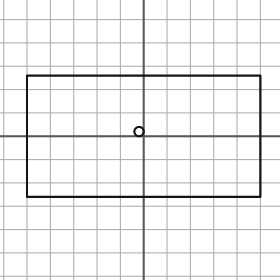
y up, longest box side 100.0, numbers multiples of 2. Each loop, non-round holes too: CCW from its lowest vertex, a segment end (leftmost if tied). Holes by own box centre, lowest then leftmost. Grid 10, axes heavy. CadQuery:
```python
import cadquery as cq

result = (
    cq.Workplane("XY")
    .moveTo(-50.0, -26.0)
    .lineTo(50.0, -26.0)
    .lineTo(50.0, 26.0)
    .lineTo(-50.0, 26.0)
    .close()
    .moveTo(-2.0, 2.0)
    .circle(2.0)
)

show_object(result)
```